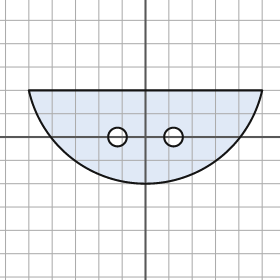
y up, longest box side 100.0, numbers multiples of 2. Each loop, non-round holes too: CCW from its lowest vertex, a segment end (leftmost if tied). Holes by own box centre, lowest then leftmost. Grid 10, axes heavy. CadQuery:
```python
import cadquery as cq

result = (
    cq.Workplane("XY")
    .moveTo(-50.0, 20.0)
    .threePointArc((0.0, -20.0), (50.0, 20.0))
    .close()
    .moveTo(-12.0, 0.0)
    .circle(4.0)
    .moveTo(12.0, 0.0)
    .circle(4.0)
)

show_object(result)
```